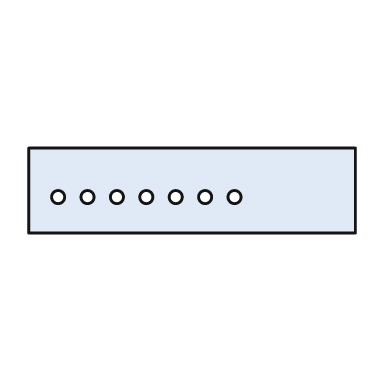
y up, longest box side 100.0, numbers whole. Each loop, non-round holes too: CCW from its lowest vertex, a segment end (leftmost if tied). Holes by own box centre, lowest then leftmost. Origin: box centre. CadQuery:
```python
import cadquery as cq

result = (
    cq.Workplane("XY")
    .moveTo(-50.0, -13.0)
    .lineTo(50.0, -13.0)
    .lineTo(50.0, 13.0)
    .lineTo(-50.0, 13.0)
    .close()
    .moveTo(-41.0, -2.0)
    .circle(2.0)
    .moveTo(-32.0, -2.0)
    .circle(2.0)
    .moveTo(-23.0, -2.0)
    .circle(2.0)
    .moveTo(-14.0, -2.0)
    .circle(2.0)
    .moveTo(-5.0, -2.0)
    .circle(2.0)
    .moveTo(4.0, -2.0)
    .circle(2.0)
    .moveTo(13.0, -2.0)
    .circle(2.0)
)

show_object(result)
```